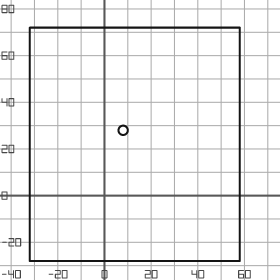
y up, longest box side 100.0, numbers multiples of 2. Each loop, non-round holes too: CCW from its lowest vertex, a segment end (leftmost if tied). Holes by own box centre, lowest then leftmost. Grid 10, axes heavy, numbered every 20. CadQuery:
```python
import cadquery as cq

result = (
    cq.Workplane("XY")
    .moveTo(-32.0, -28.0)
    .lineTo(58.0, -28.0)
    .lineTo(58.0, 72.0)
    .lineTo(-32.0, 72.0)
    .close()
    .moveTo(8.0, 28.0)
    .circle(2.0)
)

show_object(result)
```